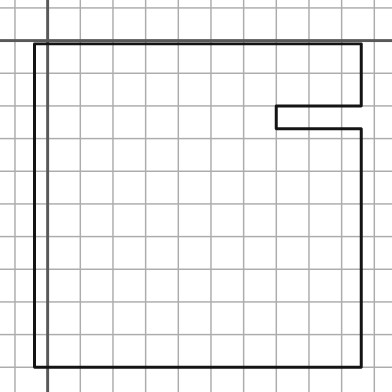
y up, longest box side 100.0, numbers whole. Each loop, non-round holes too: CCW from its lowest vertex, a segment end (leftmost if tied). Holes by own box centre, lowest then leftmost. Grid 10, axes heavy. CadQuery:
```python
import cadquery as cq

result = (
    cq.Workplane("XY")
    .moveTo(-4.0, -100.0)
    .lineTo(96.0, -100.0)
    .lineTo(96.0, -27.0)
    .lineTo(70.0, -27.0)
    .lineTo(70.0, -20.0)
    .lineTo(96.0, -20.0)
    .lineTo(96.0, -1.0)
    .lineTo(-4.0, -1.0)
    .close()
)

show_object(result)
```